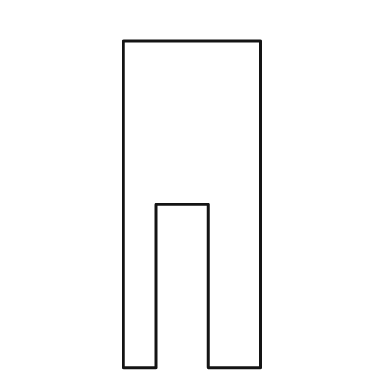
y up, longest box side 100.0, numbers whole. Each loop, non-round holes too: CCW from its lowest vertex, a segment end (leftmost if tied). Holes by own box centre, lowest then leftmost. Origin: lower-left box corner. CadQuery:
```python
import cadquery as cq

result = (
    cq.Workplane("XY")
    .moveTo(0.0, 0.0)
    .lineTo(10.0, 0.0)
    .lineTo(10.0, 50.0)
    .lineTo(26.0, 50.0)
    .lineTo(26.0, 0.0)
    .lineTo(42.0, 0.0)
    .lineTo(42.0, 100.0)
    .lineTo(0.0, 100.0)
    .close()
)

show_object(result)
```